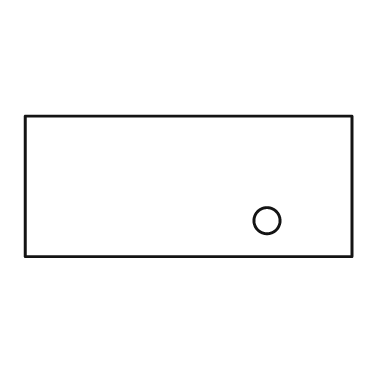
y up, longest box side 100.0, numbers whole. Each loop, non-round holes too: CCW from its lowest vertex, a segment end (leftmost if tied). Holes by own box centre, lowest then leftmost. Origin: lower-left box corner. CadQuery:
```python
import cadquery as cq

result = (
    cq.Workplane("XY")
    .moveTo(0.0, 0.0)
    .lineTo(100.0, 0.0)
    .lineTo(100.0, 43.0)
    .lineTo(0.0, 43.0)
    .close()
    .moveTo(74.0, 11.0)
    .circle(4.0)
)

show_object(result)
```